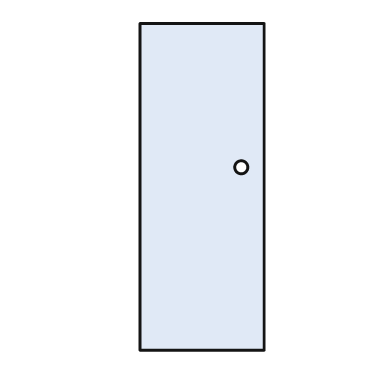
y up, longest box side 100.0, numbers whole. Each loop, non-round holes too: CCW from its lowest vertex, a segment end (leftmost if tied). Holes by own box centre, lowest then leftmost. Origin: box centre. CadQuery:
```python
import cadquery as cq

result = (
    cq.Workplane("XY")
    .moveTo(-19.0, -50.0)
    .lineTo(19.0, -50.0)
    .lineTo(19.0, 50.0)
    .lineTo(-19.0, 50.0)
    .close()
    .moveTo(12.0, 6.0)
    .circle(2.0)
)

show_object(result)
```